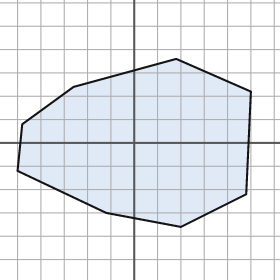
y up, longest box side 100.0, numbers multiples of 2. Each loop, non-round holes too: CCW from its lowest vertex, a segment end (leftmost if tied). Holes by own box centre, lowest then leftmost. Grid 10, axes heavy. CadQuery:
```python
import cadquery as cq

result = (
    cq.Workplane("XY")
    .moveTo(20.0, -36.0)
    .lineTo(48.0, -22.0)
    .lineTo(50.0, 22.0)
    .lineTo(18.0, 36.0)
    .lineTo(-26.0, 24.0)
    .lineTo(-48.0, 8.0)
    .lineTo(-50.0, -12.0)
    .lineTo(-12.0, -30.0)
    .close()
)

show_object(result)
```